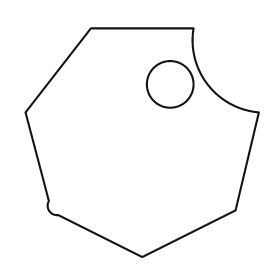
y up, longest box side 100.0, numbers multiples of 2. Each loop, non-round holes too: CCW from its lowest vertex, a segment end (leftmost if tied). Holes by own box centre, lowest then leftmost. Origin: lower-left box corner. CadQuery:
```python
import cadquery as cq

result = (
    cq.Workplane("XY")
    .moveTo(50.0, 0.0)
    .lineTo(90.0, 20.0)
    .lineTo(100.0, 62.0)
    .threePointArc((78.0, 74.0), (72.0, 98.0))
    .lineTo(28.0, 98.0)
    .lineTo(0.0, 62.0)
    .lineTo(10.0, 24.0)
    .threePointArc((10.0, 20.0), (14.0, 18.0))
    .close()
    .moveTo(62.0, 74.0)
    .circle(10.0)
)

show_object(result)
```